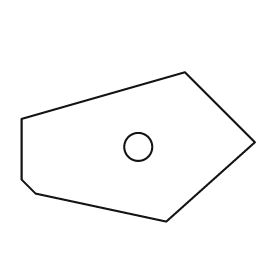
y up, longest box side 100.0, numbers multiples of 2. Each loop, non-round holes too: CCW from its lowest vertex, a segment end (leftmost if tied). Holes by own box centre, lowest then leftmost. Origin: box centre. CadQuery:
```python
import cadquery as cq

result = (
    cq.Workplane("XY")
    .moveTo(12.0, -32.0)
    .lineTo(50.0, 2.0)
    .lineTo(20.0, 32.0)
    .lineTo(-50.0, 12.0)
    .lineTo(-50.0, -14.0)
    .lineTo(-44.0, -20.0)
    .close()
    .moveTo(0.0, 0.0)
    .circle(6.0)
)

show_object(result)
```